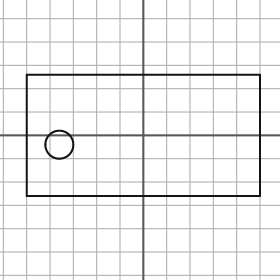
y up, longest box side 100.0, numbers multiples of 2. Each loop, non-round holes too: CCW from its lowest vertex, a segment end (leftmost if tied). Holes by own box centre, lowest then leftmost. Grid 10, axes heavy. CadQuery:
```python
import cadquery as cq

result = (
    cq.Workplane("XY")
    .moveTo(-50.0, -26.0)
    .lineTo(50.0, -26.0)
    .lineTo(50.0, 26.0)
    .lineTo(-50.0, 26.0)
    .close()
    .moveTo(-36.0, -4.0)
    .circle(6.0)
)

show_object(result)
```